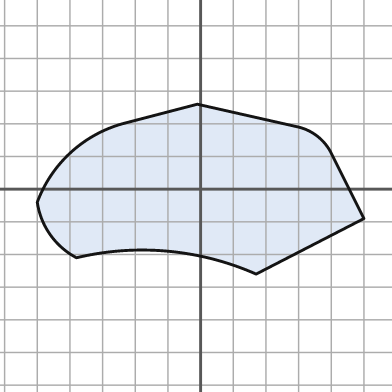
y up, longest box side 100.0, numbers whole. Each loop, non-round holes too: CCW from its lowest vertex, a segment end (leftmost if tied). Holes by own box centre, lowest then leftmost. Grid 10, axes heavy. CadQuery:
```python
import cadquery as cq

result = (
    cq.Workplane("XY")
    .moveTo(17.0, -26.0)
    .lineTo(50.0, -9.0)
    .lineTo(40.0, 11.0)
    .threePointArc((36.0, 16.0), (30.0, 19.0))
    .lineTo(-1.0, 26.0)
    .lineTo(-24.0, 20.0)
    .threePointArc((-40.0, 11.0), (-50.0, -4.0))
    .threePointArc((-46.0, -14.0), (-38.0, -21.0))
    .threePointArc((-10.0, -19.0), (17.0, -26.0))
    .close()
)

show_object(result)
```